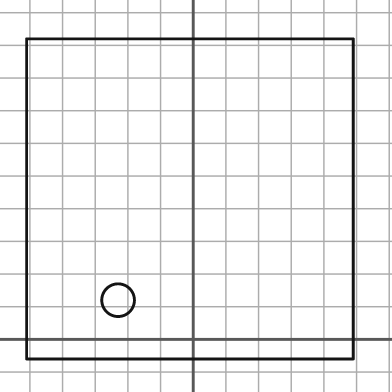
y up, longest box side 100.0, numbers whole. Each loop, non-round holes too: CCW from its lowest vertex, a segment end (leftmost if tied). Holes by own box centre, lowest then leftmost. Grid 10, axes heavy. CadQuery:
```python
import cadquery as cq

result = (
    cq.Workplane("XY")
    .moveTo(-51.0, -6.0)
    .lineTo(49.0, -6.0)
    .lineTo(49.0, 92.0)
    .lineTo(-51.0, 92.0)
    .close()
    .moveTo(-23.0, 12.0)
    .circle(5.0)
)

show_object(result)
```